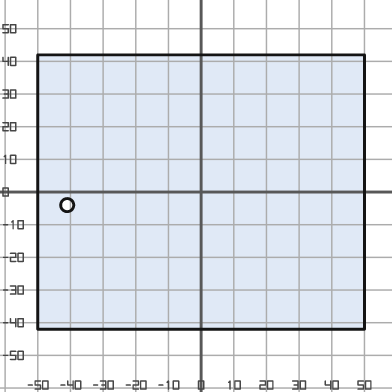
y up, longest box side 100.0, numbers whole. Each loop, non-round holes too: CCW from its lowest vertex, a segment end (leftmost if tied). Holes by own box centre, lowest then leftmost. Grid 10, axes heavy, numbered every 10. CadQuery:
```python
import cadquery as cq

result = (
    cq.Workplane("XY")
    .moveTo(-50.0, -42.0)
    .lineTo(50.0, -42.0)
    .lineTo(50.0, 42.0)
    .lineTo(-50.0, 42.0)
    .close()
    .moveTo(-41.0, -4.0)
    .circle(2.0)
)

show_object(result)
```